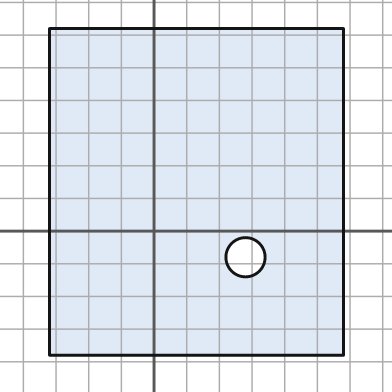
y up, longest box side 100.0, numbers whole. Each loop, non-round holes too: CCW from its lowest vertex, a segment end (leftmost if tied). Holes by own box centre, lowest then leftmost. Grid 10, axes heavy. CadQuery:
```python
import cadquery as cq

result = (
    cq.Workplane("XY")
    .moveTo(-32.0, -38.0)
    .lineTo(58.0, -38.0)
    .lineTo(58.0, 62.0)
    .lineTo(-32.0, 62.0)
    .close()
    .moveTo(28.0, -8.0)
    .circle(6.0)
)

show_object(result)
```